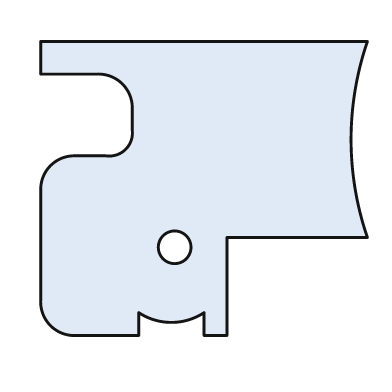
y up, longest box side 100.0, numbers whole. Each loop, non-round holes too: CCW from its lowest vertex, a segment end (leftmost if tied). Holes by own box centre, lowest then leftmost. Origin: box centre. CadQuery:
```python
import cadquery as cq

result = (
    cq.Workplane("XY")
    .moveTo(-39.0, -45.0)
    .lineTo(-20.0, -45.0)
    .lineTo(-20.0, -38.0)
    .threePointArc((-10.0, -41.0), (0.0, -38.0))
    .lineTo(0.0, -45.0)
    .lineTo(7.0, -45.0)
    .lineTo(7.0, -15.0)
    .lineTo(50.0, -15.0)
    .threePointArc((45.0, 15.0), (50.0, 45.0))
    .lineTo(-50.0, 45.0)
    .lineTo(-50.0, 35.0)
    .lineTo(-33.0, 35.0)
    .threePointArc((-25.0, 32.0), (-22.0, 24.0))
    .lineTo(-22.0, 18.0)
    .threePointArc((-24.0, 12.0), (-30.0, 10.0))
    .lineTo(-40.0, 10.0)
    .threePointArc((-47.0, 7.0), (-50.0, 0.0))
    .lineTo(-50.0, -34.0)
    .threePointArc((-47.0, -42.0), (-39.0, -45.0))
    .close()
    .moveTo(-9.0, -18.0)
    .circle(5.0)
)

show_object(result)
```